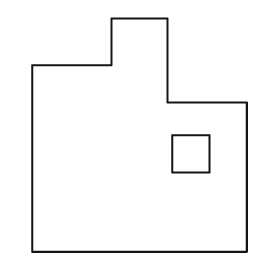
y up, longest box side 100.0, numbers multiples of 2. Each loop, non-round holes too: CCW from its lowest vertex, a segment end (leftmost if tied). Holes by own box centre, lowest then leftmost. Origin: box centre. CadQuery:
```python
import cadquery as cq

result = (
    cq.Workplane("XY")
    .moveTo(-46.0, -50.0)
    .lineTo(46.0, -50.0)
    .lineTo(46.0, 14.0)
    .lineTo(12.0, 14.0)
    .lineTo(12.0, 50.0)
    .lineTo(-12.0, 50.0)
    .lineTo(-12.0, 30.0)
    .lineTo(-46.0, 30.0)
    .close()
    .moveTo(14.0, -16.0)
    .lineTo(30.0, -16.0)
    .lineTo(30.0, 0.0)
    .lineTo(14.0, 0.0)
    .close()
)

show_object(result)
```